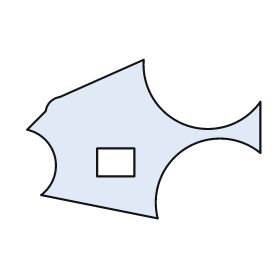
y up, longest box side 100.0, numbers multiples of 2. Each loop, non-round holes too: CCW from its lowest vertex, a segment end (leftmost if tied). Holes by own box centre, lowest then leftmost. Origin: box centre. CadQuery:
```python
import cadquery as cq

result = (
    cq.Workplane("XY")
    .moveTo(6.0, -34.0)
    .threePointArc((18.0, -4.0), (50.0, -6.0))
    .lineTo(50.0, 16.0)
    .threePointArc((18.0, 6.0), (0.0, 34.0))
    .lineTo(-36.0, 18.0)
    .threePointArc((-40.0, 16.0), (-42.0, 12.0))
    .lineTo(-50.0, 4.0)
    .threePointArc((-38.0, -8.0), (-44.0, -24.0))
    .close()
    .moveTo(-20.0, -16.0)
    .lineTo(-4.0, -16.0)
    .lineTo(-4.0, -4.0)
    .lineTo(-20.0, -4.0)
    .close()
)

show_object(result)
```